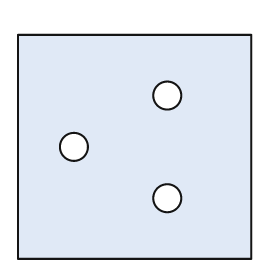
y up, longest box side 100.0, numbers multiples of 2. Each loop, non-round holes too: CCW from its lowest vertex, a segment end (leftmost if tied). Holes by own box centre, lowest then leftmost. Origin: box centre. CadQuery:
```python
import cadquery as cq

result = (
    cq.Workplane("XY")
    .moveTo(-50.0, -48.0)
    .lineTo(50.0, -48.0)
    .lineTo(50.0, 48.0)
    .lineTo(-50.0, 48.0)
    .close()
    .moveTo(14.0, -22.0)
    .circle(6.0)
    .moveTo(-26.0, 0.0)
    .circle(6.0)
    .moveTo(14.0, 22.0)
    .circle(6.0)
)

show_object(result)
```